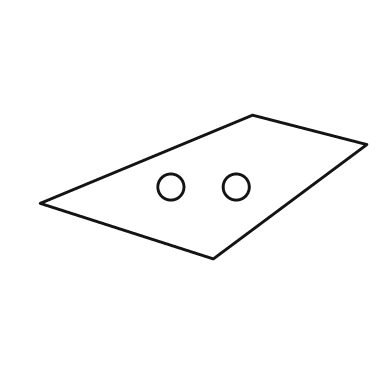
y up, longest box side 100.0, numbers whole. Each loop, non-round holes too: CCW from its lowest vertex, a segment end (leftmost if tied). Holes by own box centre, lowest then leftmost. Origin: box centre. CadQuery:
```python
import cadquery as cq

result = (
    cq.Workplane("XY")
    .moveTo(3.0, -22.0)
    .lineTo(50.0, 13.0)
    .lineTo(15.0, 22.0)
    .lineTo(-50.0, -5.0)
    .close()
    .moveTo(-10.0, 0.0)
    .circle(4.0)
    .moveTo(10.0, 0.0)
    .circle(4.0)
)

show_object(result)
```